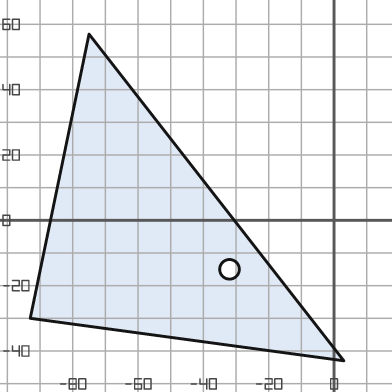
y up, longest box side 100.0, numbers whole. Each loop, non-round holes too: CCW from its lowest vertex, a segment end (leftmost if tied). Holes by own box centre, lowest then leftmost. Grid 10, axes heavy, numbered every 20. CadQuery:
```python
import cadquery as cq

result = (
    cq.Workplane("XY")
    .moveTo(3.0, -43.0)
    .lineTo(-75.0, 57.0)
    .lineTo(-93.0, -30.0)
    .close()
    .moveTo(-32.0, -15.0)
    .circle(3.0)
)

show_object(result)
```